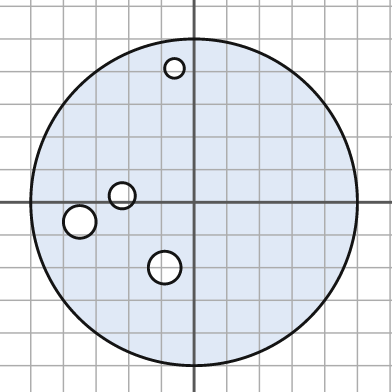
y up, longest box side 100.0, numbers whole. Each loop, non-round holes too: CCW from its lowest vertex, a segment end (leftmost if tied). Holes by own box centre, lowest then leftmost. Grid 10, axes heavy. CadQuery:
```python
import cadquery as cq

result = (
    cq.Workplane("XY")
    .moveTo(0.0, 0.0)
    .circle(50.0)
    .moveTo(-9.0, -20.0)
    .circle(5.0)
    .moveTo(-35.0, -6.0)
    .circle(5.0)
    .moveTo(-22.0, 2.0)
    .circle(4.0)
    .moveTo(-6.0, 41.0)
    .circle(3.0)
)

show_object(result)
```